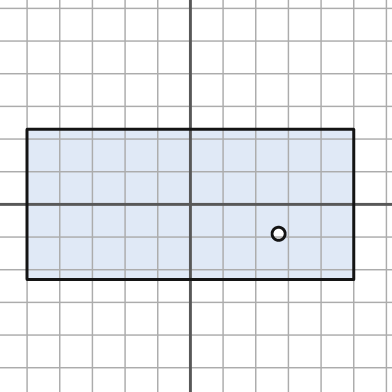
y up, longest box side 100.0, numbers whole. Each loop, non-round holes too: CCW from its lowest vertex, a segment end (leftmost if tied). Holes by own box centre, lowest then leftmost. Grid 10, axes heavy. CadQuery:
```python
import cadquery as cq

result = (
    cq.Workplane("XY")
    .moveTo(-50.0, -23.0)
    .lineTo(50.0, -23.0)
    .lineTo(50.0, 23.0)
    .lineTo(-50.0, 23.0)
    .close()
    .moveTo(27.0, -9.0)
    .circle(2.0)
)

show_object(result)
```